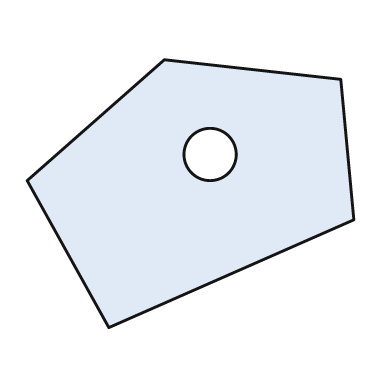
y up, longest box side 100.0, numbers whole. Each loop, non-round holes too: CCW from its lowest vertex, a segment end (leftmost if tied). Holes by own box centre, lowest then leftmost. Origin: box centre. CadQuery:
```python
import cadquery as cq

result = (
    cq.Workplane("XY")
    .moveTo(-25.0, -41.0)
    .lineTo(50.0, -8.0)
    .lineTo(46.0, 35.0)
    .lineTo(-8.0, 41.0)
    .lineTo(-50.0, 4.0)
    .close()
    .moveTo(6.0, 12.0)
    .circle(8.0)
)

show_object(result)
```